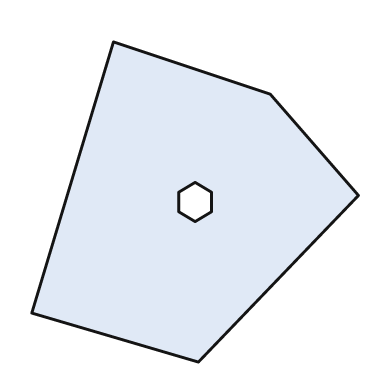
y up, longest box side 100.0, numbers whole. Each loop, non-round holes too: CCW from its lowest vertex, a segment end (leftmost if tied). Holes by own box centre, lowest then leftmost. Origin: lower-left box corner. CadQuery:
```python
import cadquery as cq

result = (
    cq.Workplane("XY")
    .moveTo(51.0, 0.0)
    .lineTo(100.0, 51.0)
    .lineTo(73.0, 82.0)
    .lineTo(25.0, 98.0)
    .lineTo(0.0, 15.0)
    .close()
    .moveTo(50.0, 43.0)
    .lineTo(55.0, 46.0)
    .lineTo(55.0, 52.0)
    .lineTo(50.0, 55.0)
    .lineTo(45.0, 52.0)
    .lineTo(45.0, 46.0)
    .close()
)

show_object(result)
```